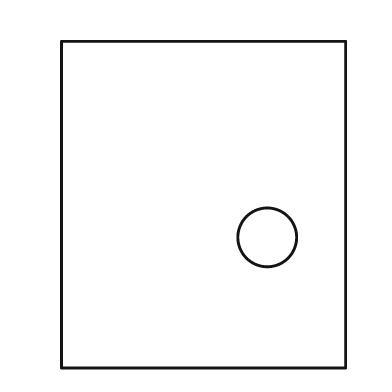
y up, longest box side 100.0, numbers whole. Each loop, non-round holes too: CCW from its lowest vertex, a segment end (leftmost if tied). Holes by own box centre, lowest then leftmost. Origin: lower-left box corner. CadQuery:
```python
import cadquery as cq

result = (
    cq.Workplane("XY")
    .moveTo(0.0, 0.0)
    .lineTo(87.0, 0.0)
    .lineTo(87.0, 100.0)
    .lineTo(0.0, 100.0)
    .close()
    .moveTo(63.0, 40.0)
    .circle(9.0)
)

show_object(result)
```